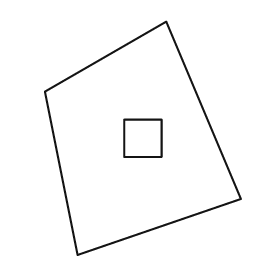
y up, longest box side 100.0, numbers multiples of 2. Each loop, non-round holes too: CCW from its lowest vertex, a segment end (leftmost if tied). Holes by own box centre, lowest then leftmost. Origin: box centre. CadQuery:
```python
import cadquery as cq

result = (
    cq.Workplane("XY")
    .moveTo(-28.0, -50.0)
    .lineTo(42.0, -26.0)
    .lineTo(10.0, 50.0)
    .lineTo(-42.0, 20.0)
    .close()
    .moveTo(-8.0, -8.0)
    .lineTo(8.0, -8.0)
    .lineTo(8.0, 8.0)
    .lineTo(-8.0, 8.0)
    .close()
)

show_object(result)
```